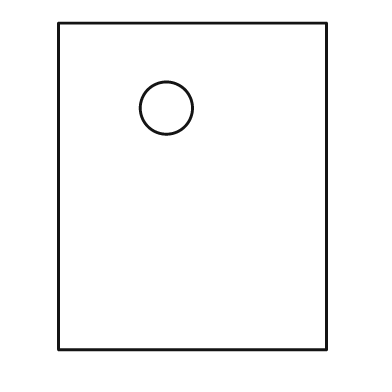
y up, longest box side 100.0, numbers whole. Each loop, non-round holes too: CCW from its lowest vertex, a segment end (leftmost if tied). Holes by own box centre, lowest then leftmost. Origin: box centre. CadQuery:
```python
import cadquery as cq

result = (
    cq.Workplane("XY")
    .moveTo(-41.0, -50.0)
    .lineTo(41.0, -50.0)
    .lineTo(41.0, 50.0)
    .lineTo(-41.0, 50.0)
    .close()
    .moveTo(-8.0, 24.0)
    .circle(8.0)
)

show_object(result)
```